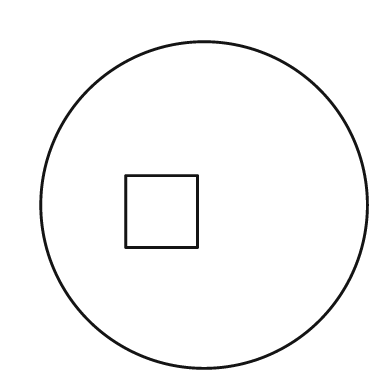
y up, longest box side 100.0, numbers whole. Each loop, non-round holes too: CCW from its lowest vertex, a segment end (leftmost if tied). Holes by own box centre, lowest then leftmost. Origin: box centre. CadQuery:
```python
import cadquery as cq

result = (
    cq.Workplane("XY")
    .moveTo(0.0, 0.0)
    .circle(50.0)
    .moveTo(-24.0, -13.0)
    .lineTo(-2.0, -13.0)
    .lineTo(-2.0, 9.0)
    .lineTo(-24.0, 9.0)
    .close()
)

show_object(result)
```